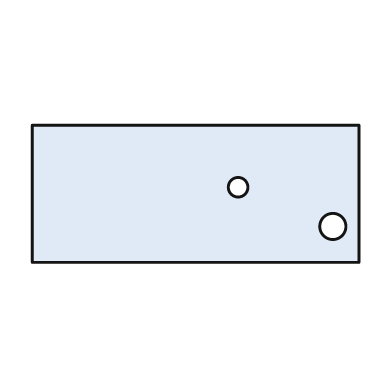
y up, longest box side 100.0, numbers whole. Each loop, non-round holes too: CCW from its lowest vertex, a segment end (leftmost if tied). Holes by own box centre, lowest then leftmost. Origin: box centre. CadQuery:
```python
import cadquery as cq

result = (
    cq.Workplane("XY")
    .moveTo(-50.0, -21.0)
    .lineTo(50.0, -21.0)
    .lineTo(50.0, 21.0)
    .lineTo(-50.0, 21.0)
    .close()
    .moveTo(42.0, -10.0)
    .circle(4.0)
    .moveTo(13.0, 2.0)
    .circle(3.0)
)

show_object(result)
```